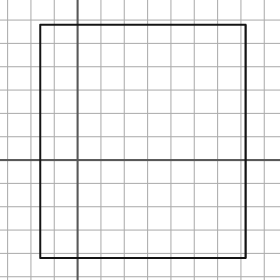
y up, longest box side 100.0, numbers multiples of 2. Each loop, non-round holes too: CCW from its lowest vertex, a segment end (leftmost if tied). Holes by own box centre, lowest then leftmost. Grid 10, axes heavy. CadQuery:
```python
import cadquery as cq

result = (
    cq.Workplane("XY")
    .moveTo(-16.0, -42.0)
    .lineTo(72.0, -42.0)
    .lineTo(72.0, 58.0)
    .lineTo(-16.0, 58.0)
    .close()
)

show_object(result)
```